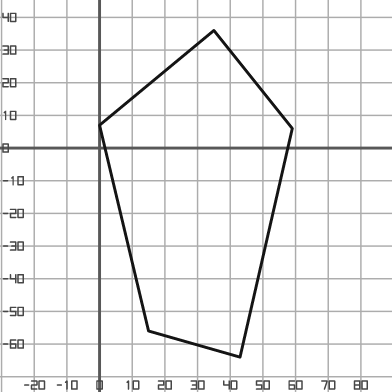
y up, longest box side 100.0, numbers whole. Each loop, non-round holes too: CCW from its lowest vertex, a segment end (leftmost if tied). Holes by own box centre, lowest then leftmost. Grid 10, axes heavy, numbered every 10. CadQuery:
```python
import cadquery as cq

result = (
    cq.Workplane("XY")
    .moveTo(43.0, -64.0)
    .lineTo(59.0, 6.0)
    .lineTo(35.0, 36.0)
    .lineTo(0.0, 7.0)
    .lineTo(15.0, -56.0)
    .close()
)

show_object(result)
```